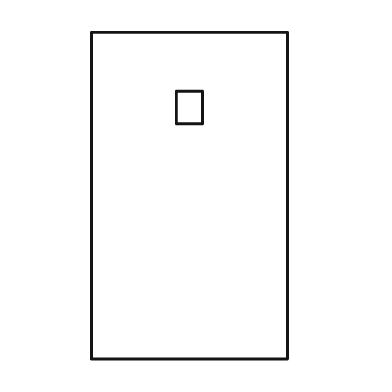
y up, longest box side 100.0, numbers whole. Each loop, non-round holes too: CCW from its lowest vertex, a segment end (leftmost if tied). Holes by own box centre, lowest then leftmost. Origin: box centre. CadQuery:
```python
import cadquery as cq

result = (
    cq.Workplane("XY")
    .moveTo(-30.0, -50.0)
    .lineTo(30.0, -50.0)
    .lineTo(30.0, 50.0)
    .lineTo(-30.0, 50.0)
    .close()
    .moveTo(-4.0, 22.0)
    .lineTo(4.0, 22.0)
    .lineTo(4.0, 32.0)
    .lineTo(-4.0, 32.0)
    .close()
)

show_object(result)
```